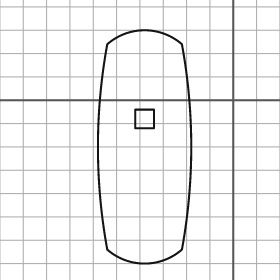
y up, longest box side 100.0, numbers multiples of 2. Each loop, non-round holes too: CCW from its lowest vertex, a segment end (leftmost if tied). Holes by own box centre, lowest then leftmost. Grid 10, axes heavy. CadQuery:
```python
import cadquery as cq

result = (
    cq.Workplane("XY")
    .moveTo(-54.0, -64.0)
    .threePointArc((-38.0, -70.0), (-22.0, -64.0))
    .threePointArc((-18.0, -20.0), (-22.0, 24.0))
    .threePointArc((-38.0, 30.0), (-54.0, 24.0))
    .threePointArc((-58.0, -20.0), (-54.0, -64.0))
    .close()
    .moveTo(-42.0, -12.0)
    .lineTo(-34.0, -12.0)
    .lineTo(-34.0, -4.0)
    .lineTo(-42.0, -4.0)
    .close()
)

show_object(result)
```